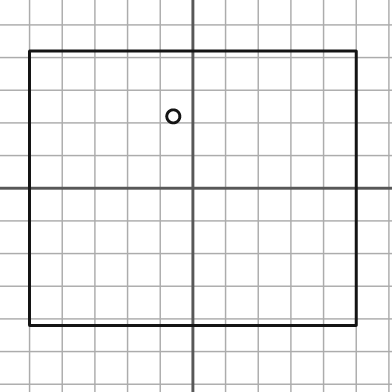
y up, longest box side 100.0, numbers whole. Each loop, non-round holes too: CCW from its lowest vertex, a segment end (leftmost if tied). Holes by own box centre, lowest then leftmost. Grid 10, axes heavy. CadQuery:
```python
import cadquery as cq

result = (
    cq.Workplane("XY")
    .moveTo(-50.0, -42.0)
    .lineTo(50.0, -42.0)
    .lineTo(50.0, 42.0)
    .lineTo(-50.0, 42.0)
    .close()
    .moveTo(-6.0, 22.0)
    .circle(2.0)
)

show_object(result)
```